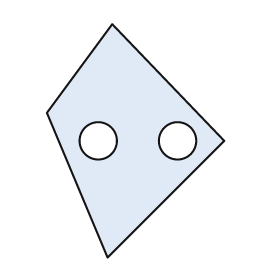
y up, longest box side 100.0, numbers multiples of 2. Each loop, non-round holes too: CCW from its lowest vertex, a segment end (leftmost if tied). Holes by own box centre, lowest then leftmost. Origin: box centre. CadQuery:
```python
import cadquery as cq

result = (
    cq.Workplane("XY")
    .moveTo(-12.0, -50.0)
    .lineTo(38.0, 0.0)
    .lineTo(-10.0, 50.0)
    .lineTo(-38.0, 12.0)
    .close()
    .moveTo(-16.0, 0.0)
    .circle(8.0)
    .moveTo(18.0, 0.0)
    .circle(8.0)
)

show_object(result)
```